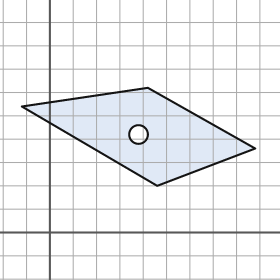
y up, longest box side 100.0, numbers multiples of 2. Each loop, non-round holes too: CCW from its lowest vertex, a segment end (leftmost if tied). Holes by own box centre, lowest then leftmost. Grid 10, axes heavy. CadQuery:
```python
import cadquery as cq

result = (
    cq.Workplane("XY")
    .moveTo(46.0, 20.0)
    .lineTo(88.0, 36.0)
    .lineTo(42.0, 62.0)
    .lineTo(-12.0, 54.0)
    .close()
    .moveTo(38.0, 42.0)
    .circle(4.0)
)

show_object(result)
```